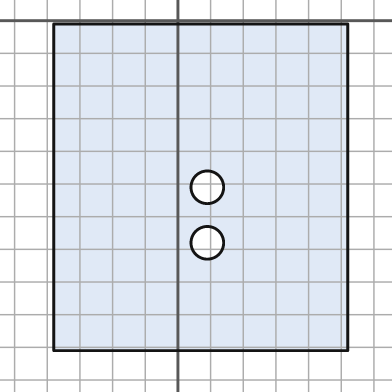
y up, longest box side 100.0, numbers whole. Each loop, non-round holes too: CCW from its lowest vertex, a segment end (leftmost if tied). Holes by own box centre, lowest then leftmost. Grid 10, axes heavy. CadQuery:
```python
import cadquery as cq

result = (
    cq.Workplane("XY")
    .moveTo(-38.0, -101.0)
    .lineTo(52.0, -101.0)
    .lineTo(52.0, -1.0)
    .lineTo(-38.0, -1.0)
    .close()
    .moveTo(9.0, -68.0)
    .circle(5.0)
    .moveTo(9.0, -51.0)
    .circle(5.0)
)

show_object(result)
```